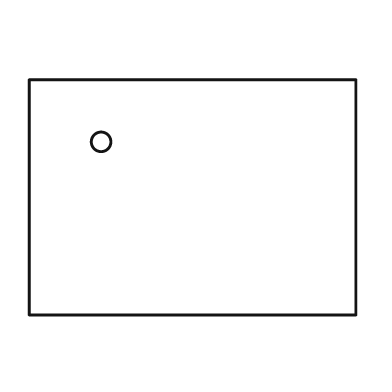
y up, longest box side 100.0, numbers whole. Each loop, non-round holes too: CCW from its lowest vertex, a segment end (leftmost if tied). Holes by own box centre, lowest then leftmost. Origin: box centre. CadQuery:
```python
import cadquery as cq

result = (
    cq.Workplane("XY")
    .moveTo(-50.0, -36.0)
    .lineTo(50.0, -36.0)
    .lineTo(50.0, 36.0)
    .lineTo(-50.0, 36.0)
    .close()
    .moveTo(-28.0, 17.0)
    .circle(3.0)
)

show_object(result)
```